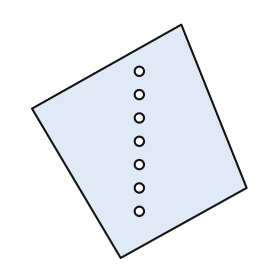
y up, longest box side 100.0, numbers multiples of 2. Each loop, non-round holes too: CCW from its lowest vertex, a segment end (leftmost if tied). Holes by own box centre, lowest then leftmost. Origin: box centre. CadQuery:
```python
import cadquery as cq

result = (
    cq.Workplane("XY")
    .moveTo(-8.0, -50.0)
    .lineTo(46.0, -20.0)
    .lineTo(18.0, 50.0)
    .lineTo(-46.0, 14.0)
    .close()
    .moveTo(0.0, -30.0)
    .circle(2.0)
    .moveTo(0.0, -20.0)
    .circle(2.0)
    .moveTo(0.0, -10.0)
    .circle(2.0)
    .moveTo(0.0, 0.0)
    .circle(2.0)
    .moveTo(0.0, 10.0)
    .circle(2.0)
    .moveTo(0.0, 20.0)
    .circle(2.0)
    .moveTo(0.0, 30.0)
    .circle(2.0)
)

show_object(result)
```